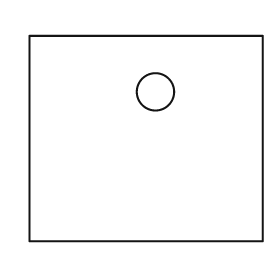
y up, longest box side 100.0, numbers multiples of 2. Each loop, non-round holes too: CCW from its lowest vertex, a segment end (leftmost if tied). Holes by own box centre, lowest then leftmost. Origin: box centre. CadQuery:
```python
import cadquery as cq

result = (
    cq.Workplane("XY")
    .moveTo(-50.0, -44.0)
    .lineTo(50.0, -44.0)
    .lineTo(50.0, 44.0)
    .lineTo(-50.0, 44.0)
    .close()
    .moveTo(4.0, 20.0)
    .circle(8.0)
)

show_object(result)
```